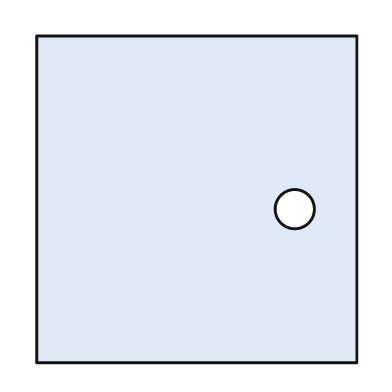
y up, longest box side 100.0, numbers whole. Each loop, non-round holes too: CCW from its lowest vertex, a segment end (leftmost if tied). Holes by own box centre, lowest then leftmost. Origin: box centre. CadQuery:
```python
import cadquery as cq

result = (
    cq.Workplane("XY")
    .moveTo(-49.0, -50.0)
    .lineTo(49.0, -50.0)
    .lineTo(49.0, 50.0)
    .lineTo(-49.0, 50.0)
    .close()
    .moveTo(30.0, -3.0)
    .circle(6.0)
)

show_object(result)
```